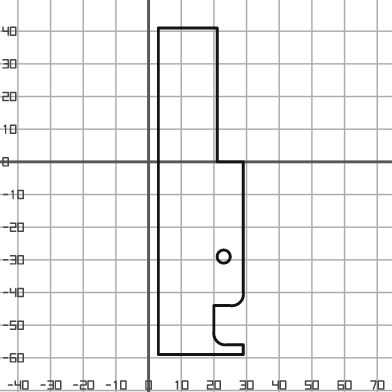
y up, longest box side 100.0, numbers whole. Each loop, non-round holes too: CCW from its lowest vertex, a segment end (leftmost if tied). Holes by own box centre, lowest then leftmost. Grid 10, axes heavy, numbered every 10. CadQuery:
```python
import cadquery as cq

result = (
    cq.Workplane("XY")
    .moveTo(3.0, -59.0)
    .lineTo(29.0, -59.0)
    .lineTo(29.0, -56.0)
    .lineTo(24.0, -56.0)
    .threePointArc((21.0, -55.0), (20.0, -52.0))
    .lineTo(20.0, -44.0)
    .lineTo(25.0, -44.0)
    .threePointArc((28.0, -43.0), (29.0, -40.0))
    .lineTo(29.0, 0.0)
    .lineTo(21.0, 0.0)
    .lineTo(21.0, 41.0)
    .lineTo(3.0, 41.0)
    .close()
    .moveTo(23.0, -29.0)
    .circle(2.0)
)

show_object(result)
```